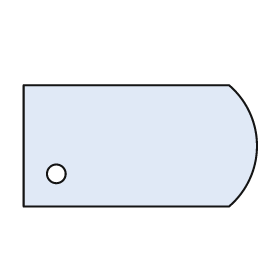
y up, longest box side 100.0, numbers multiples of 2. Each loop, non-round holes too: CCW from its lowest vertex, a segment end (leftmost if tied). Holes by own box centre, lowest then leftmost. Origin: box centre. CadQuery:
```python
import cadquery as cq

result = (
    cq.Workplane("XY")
    .moveTo(-50.0, -26.0)
    .lineTo(38.0, -26.0)
    .threePointArc((50.0, 0.0), (38.0, 26.0))
    .lineTo(-50.0, 26.0)
    .close()
    .moveTo(-36.0, -12.0)
    .circle(4.0)
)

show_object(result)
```